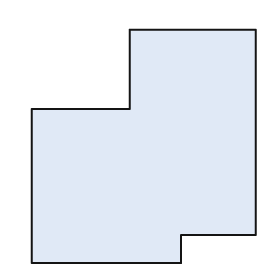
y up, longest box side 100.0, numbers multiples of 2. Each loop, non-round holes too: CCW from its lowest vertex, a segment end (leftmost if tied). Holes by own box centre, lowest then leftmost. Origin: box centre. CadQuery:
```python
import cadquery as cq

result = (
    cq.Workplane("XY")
    .moveTo(-48.0, -50.0)
    .lineTo(16.0, -50.0)
    .lineTo(16.0, -38.0)
    .lineTo(48.0, -38.0)
    .lineTo(48.0, 50.0)
    .lineTo(-6.0, 50.0)
    .lineTo(-6.0, 16.0)
    .lineTo(-48.0, 16.0)
    .close()
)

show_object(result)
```